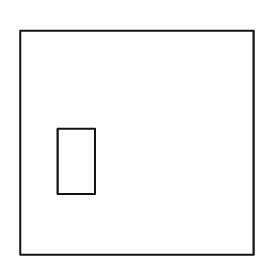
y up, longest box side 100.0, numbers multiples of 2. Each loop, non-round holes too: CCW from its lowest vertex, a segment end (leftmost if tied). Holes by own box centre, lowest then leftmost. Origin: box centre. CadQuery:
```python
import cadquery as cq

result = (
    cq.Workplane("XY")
    .moveTo(-50.0, -48.0)
    .lineTo(50.0, -48.0)
    .lineTo(50.0, 48.0)
    .lineTo(-50.0, 48.0)
    .close()
    .moveTo(-34.0, -22.0)
    .lineTo(-18.0, -22.0)
    .lineTo(-18.0, 6.0)
    .lineTo(-34.0, 6.0)
    .close()
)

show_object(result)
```